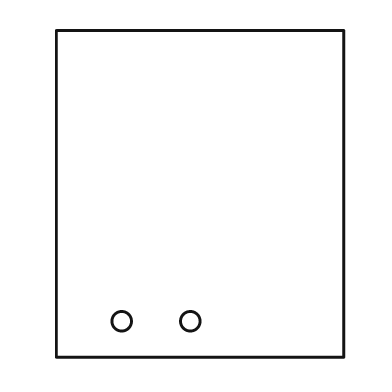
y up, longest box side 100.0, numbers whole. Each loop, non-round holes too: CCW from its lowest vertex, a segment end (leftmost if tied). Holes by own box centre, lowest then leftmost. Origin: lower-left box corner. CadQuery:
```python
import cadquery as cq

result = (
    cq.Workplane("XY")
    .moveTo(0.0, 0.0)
    .lineTo(88.0, 0.0)
    .lineTo(88.0, 100.0)
    .lineTo(0.0, 100.0)
    .close()
    .moveTo(20.0, 11.0)
    .circle(3.0)
    .moveTo(41.0, 11.0)
    .circle(3.0)
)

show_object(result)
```